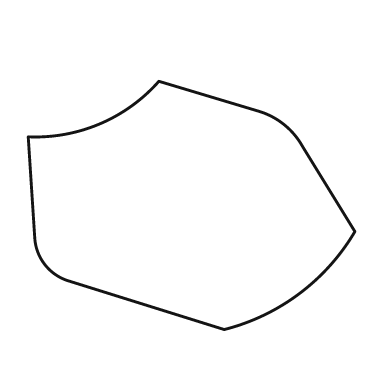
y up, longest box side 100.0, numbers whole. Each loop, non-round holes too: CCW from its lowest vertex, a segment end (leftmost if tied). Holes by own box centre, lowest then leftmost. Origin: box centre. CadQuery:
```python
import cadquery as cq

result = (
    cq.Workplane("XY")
    .moveTo(10.0, -38.0)
    .threePointArc((33.0, -27.0), (50.0, -8.0))
    .lineTo(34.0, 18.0)
    .threePointArc((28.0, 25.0), (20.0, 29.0))
    .lineTo(-10.0, 38.0)
    .threePointArc((-28.0, 25.0), (-50.0, 21.0))
    .lineTo(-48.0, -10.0)
    .threePointArc((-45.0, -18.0), (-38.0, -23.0))
    .close()
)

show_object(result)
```